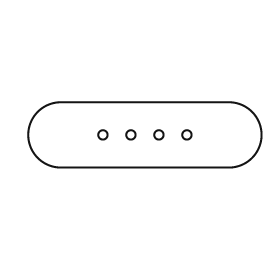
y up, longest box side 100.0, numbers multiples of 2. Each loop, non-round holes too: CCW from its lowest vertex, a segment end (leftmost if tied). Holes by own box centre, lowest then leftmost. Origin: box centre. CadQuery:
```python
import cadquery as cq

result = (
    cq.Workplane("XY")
    .moveTo(-36.0, -14.0)
    .lineTo(36.0, -14.0)
    .threePointArc((50.0, 0.0), (36.0, 14.0))
    .lineTo(-36.0, 14.0)
    .threePointArc((-50.0, 0.0), (-36.0, -14.0))
    .close()
    .moveTo(-18.0, 0.0)
    .circle(2.0)
    .moveTo(-6.0, 0.0)
    .circle(2.0)
    .moveTo(6.0, 0.0)
    .circle(2.0)
    .moveTo(18.0, 0.0)
    .circle(2.0)
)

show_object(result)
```